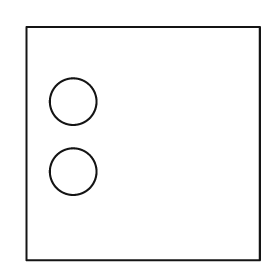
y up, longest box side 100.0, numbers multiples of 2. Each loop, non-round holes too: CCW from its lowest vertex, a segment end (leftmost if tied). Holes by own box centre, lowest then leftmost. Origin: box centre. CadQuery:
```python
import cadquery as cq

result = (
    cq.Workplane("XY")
    .moveTo(-50.0, -50.0)
    .lineTo(50.0, -50.0)
    .lineTo(50.0, 50.0)
    .lineTo(-50.0, 50.0)
    .close()
    .moveTo(-30.0, -12.0)
    .circle(10.0)
    .moveTo(-30.0, 18.0)
    .circle(10.0)
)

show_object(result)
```